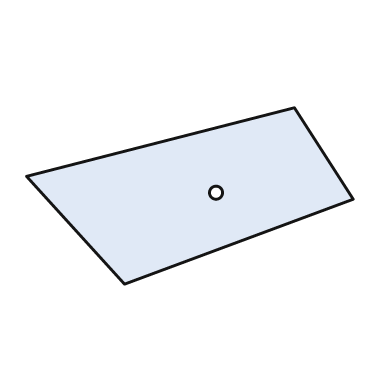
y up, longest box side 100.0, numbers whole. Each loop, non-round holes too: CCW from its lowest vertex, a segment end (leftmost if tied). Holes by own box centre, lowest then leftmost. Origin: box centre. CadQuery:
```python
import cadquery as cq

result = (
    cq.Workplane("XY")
    .moveTo(-20.0, -27.0)
    .lineTo(50.0, -1.0)
    .lineTo(32.0, 27.0)
    .lineTo(-50.0, 6.0)
    .close()
    .moveTo(8.0, 1.0)
    .circle(2.0)
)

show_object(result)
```